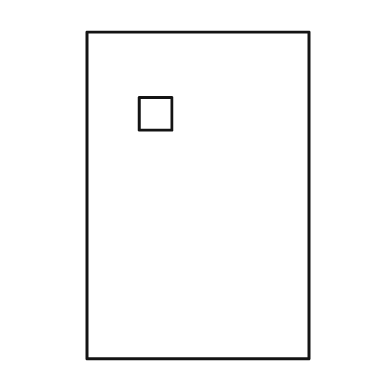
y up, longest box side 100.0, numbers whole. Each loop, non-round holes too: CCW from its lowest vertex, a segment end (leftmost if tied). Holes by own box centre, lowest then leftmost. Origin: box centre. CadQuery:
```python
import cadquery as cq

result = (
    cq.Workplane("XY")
    .moveTo(-34.0, -50.0)
    .lineTo(34.0, -50.0)
    .lineTo(34.0, 50.0)
    .lineTo(-34.0, 50.0)
    .close()
    .moveTo(-18.0, 20.0)
    .lineTo(-8.0, 20.0)
    .lineTo(-8.0, 30.0)
    .lineTo(-18.0, 30.0)
    .close()
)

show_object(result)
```